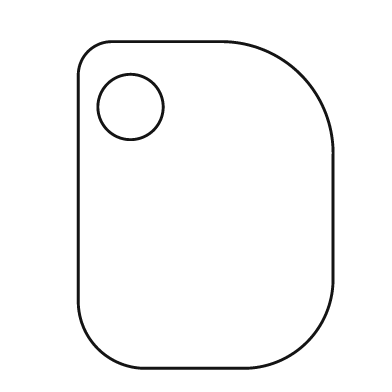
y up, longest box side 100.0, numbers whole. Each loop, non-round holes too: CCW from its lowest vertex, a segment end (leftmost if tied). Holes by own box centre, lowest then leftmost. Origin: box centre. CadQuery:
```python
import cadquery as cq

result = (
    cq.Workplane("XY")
    .moveTo(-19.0, -50.0)
    .lineTo(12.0, -50.0)
    .threePointArc((31.0, -42.0), (39.0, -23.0))
    .lineTo(39.0, 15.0)
    .threePointArc((29.0, 40.0), (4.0, 50.0))
    .lineTo(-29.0, 50.0)
    .threePointArc((-36.0, 47.0), (-39.0, 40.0))
    .lineTo(-39.0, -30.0)
    .threePointArc((-33.0, -44.0), (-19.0, -50.0))
    .close()
    .moveTo(-23.0, 30.0)
    .circle(10.0)
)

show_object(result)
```